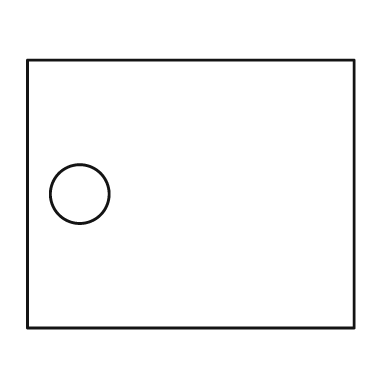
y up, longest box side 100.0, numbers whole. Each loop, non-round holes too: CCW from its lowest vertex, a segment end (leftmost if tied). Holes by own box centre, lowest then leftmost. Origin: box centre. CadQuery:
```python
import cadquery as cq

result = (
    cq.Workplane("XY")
    .moveTo(-50.0, -41.0)
    .lineTo(50.0, -41.0)
    .lineTo(50.0, 41.0)
    .lineTo(-50.0, 41.0)
    .close()
    .moveTo(-34.0, 0.0)
    .circle(9.0)
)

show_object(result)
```